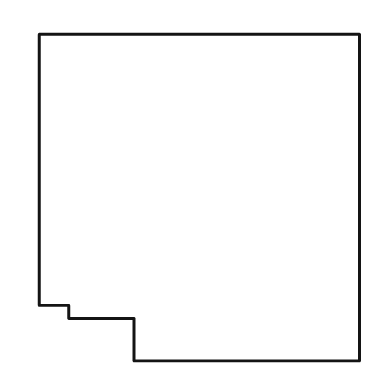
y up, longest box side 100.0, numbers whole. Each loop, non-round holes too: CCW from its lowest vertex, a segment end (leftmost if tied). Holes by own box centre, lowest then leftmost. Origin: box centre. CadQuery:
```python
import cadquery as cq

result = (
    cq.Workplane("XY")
    .moveTo(-20.0, -50.0)
    .lineTo(49.0, -50.0)
    .lineTo(49.0, 50.0)
    .lineTo(-49.0, 50.0)
    .lineTo(-49.0, -33.0)
    .lineTo(-40.0, -33.0)
    .lineTo(-40.0, -37.0)
    .lineTo(-20.0, -37.0)
    .close()
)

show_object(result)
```